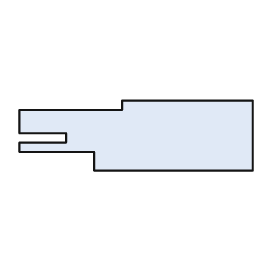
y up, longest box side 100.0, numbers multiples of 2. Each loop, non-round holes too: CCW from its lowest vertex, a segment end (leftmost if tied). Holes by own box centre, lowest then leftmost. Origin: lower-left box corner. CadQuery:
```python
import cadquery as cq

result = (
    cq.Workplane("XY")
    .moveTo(32.0, 0.0)
    .lineTo(100.0, 0.0)
    .lineTo(100.0, 30.0)
    .lineTo(44.0, 30.0)
    .lineTo(44.0, 26.0)
    .lineTo(0.0, 26.0)
    .lineTo(0.0, 16.0)
    .lineTo(20.0, 16.0)
    .lineTo(20.0, 12.0)
    .lineTo(0.0, 12.0)
    .lineTo(0.0, 8.0)
    .lineTo(32.0, 8.0)
    .close()
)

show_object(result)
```